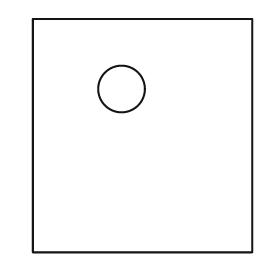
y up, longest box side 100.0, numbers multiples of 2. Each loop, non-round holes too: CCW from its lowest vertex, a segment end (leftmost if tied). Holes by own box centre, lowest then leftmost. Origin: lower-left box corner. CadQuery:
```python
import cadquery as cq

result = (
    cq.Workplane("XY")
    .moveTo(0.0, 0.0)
    .lineTo(94.0, 0.0)
    .lineTo(94.0, 100.0)
    .lineTo(0.0, 100.0)
    .close()
    .moveTo(38.0, 70.0)
    .circle(10.0)
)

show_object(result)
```